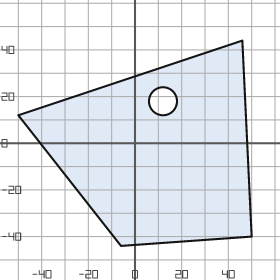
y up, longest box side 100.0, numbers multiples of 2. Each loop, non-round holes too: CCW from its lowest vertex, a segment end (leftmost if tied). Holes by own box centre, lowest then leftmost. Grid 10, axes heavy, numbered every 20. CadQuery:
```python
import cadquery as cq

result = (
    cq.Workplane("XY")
    .moveTo(-6.0, -44.0)
    .lineTo(50.0, -40.0)
    .lineTo(46.0, 44.0)
    .lineTo(-50.0, 12.0)
    .close()
    .moveTo(12.0, 18.0)
    .circle(6.0)
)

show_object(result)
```